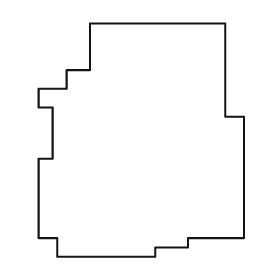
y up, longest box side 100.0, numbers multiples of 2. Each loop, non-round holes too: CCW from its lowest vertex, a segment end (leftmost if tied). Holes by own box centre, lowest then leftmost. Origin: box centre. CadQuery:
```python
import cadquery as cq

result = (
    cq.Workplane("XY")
    .moveTo(-36.0, -50.0)
    .lineTo(6.0, -50.0)
    .lineTo(6.0, -46.0)
    .lineTo(20.0, -46.0)
    .lineTo(20.0, -42.0)
    .lineTo(44.0, -42.0)
    .lineTo(44.0, 10.0)
    .lineTo(36.0, 10.0)
    .lineTo(36.0, 50.0)
    .lineTo(-22.0, 50.0)
    .lineTo(-22.0, 30.0)
    .lineTo(-32.0, 30.0)
    .lineTo(-32.0, 22.0)
    .lineTo(-44.0, 22.0)
    .lineTo(-44.0, 14.0)
    .lineTo(-38.0, 14.0)
    .lineTo(-38.0, -8.0)
    .lineTo(-44.0, -8.0)
    .lineTo(-44.0, -42.0)
    .lineTo(-36.0, -42.0)
    .close()
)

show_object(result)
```